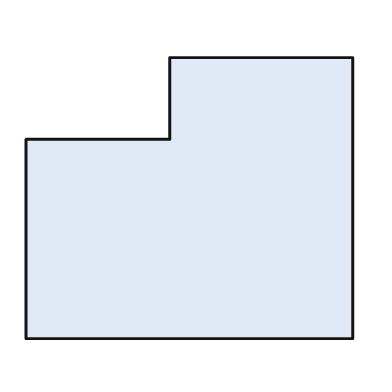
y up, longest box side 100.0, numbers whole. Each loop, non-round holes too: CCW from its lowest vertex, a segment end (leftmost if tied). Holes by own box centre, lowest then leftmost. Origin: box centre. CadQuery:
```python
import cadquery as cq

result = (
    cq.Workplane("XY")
    .moveTo(-50.0, -43.0)
    .lineTo(50.0, -43.0)
    .lineTo(50.0, 43.0)
    .lineTo(-6.0, 43.0)
    .lineTo(-6.0, 18.0)
    .lineTo(-50.0, 18.0)
    .close()
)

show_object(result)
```